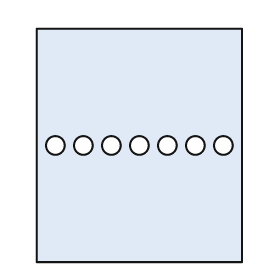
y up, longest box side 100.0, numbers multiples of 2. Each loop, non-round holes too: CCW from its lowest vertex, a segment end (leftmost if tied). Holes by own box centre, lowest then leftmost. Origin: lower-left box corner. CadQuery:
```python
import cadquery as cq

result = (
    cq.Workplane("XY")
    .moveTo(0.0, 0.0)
    .lineTo(88.0, 0.0)
    .lineTo(88.0, 100.0)
    .lineTo(0.0, 100.0)
    .close()
    .moveTo(8.0, 50.0)
    .circle(4.0)
    .moveTo(20.0, 50.0)
    .circle(4.0)
    .moveTo(32.0, 50.0)
    .circle(4.0)
    .moveTo(44.0, 50.0)
    .circle(4.0)
    .moveTo(56.0, 50.0)
    .circle(4.0)
    .moveTo(68.0, 50.0)
    .circle(4.0)
    .moveTo(80.0, 50.0)
    .circle(4.0)
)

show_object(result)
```